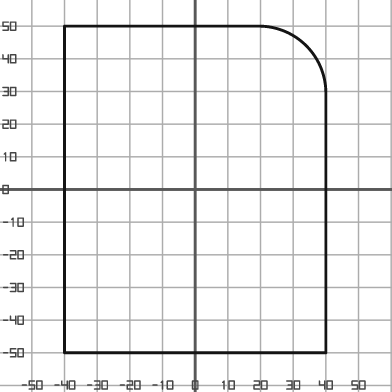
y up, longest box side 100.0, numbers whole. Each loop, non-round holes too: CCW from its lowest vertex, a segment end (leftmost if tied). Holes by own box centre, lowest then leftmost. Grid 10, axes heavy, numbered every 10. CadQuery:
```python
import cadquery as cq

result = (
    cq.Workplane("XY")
    .moveTo(-40.0, -50.0)
    .lineTo(40.0, -50.0)
    .lineTo(40.0, 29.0)
    .threePointArc((34.0, 44.0), (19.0, 50.0))
    .lineTo(-40.0, 50.0)
    .close()
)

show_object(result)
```